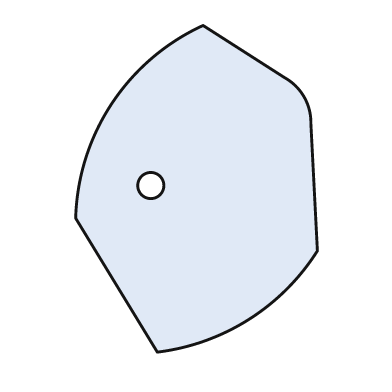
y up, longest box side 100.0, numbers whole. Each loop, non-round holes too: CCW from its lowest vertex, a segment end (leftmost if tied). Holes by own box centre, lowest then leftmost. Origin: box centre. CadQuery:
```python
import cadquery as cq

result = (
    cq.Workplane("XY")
    .moveTo(-12.0, -50.0)
    .threePointArc((16.0, -40.0), (37.0, -19.0))
    .lineTo(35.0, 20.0)
    .threePointArc((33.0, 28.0), (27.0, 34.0))
    .lineTo(2.0, 50.0)
    .threePointArc((-26.0, 26.0), (-37.0, -9.0))
    .close()
    .moveTo(-14.0, 1.0)
    .circle(4.0)
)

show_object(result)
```